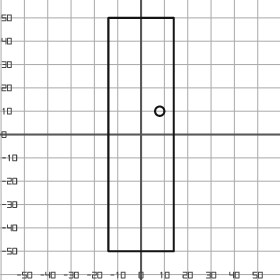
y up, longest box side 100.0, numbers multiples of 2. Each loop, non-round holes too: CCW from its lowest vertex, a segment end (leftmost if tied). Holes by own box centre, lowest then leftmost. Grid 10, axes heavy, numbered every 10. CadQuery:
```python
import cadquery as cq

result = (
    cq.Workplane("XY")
    .moveTo(-14.0, -50.0)
    .lineTo(14.0, -50.0)
    .lineTo(14.0, 50.0)
    .lineTo(-14.0, 50.0)
    .close()
    .moveTo(8.0, 10.0)
    .circle(2.0)
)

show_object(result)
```